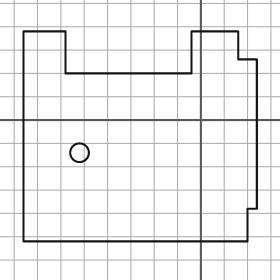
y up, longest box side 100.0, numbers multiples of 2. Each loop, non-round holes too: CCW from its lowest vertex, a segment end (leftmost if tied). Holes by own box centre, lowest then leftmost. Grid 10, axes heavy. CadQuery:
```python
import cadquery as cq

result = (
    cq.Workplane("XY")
    .moveTo(-76.0, -52.0)
    .lineTo(20.0, -52.0)
    .lineTo(20.0, -38.0)
    .lineTo(24.0, -38.0)
    .lineTo(24.0, 26.0)
    .lineTo(16.0, 26.0)
    .lineTo(16.0, 38.0)
    .lineTo(-4.0, 38.0)
    .lineTo(-4.0, 20.0)
    .lineTo(-58.0, 20.0)
    .lineTo(-58.0, 38.0)
    .lineTo(-76.0, 38.0)
    .close()
    .moveTo(-52.0, -14.0)
    .circle(4.0)
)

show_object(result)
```